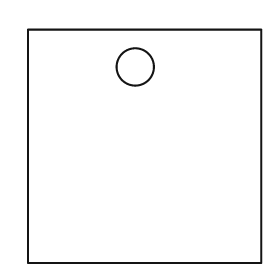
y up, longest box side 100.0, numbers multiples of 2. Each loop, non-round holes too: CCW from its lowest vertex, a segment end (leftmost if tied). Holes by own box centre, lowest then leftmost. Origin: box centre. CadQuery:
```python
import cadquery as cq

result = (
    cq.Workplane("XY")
    .moveTo(-50.0, -50.0)
    .lineTo(50.0, -50.0)
    .lineTo(50.0, 50.0)
    .lineTo(-50.0, 50.0)
    .close()
    .moveTo(-4.0, 34.0)
    .circle(8.0)
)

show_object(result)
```